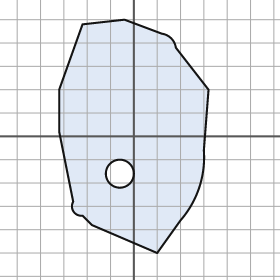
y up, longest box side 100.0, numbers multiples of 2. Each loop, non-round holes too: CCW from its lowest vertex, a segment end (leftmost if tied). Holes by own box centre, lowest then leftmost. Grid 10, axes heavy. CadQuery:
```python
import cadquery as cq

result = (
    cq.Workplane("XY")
    .moveTo(10.0, -50.0)
    .lineTo(20.0, -36.0)
    .threePointArc((28.0, -22.0), (30.0, -6.0))
    .lineTo(32.0, 20.0)
    .lineTo(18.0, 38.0)
    .threePointArc((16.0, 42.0), (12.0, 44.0))
    .lineTo(-4.0, 50.0)
    .lineTo(-22.0, 48.0)
    .lineTo(-32.0, 20.0)
    .lineTo(-32.0, 2.0)
    .lineTo(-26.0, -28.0)
    .threePointArc((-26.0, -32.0), (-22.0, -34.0))
    .lineTo(-18.0, -38.0)
    .close()
    .moveTo(-6.0, -16.0)
    .circle(6.0)
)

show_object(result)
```